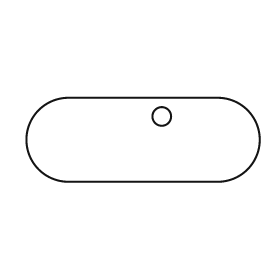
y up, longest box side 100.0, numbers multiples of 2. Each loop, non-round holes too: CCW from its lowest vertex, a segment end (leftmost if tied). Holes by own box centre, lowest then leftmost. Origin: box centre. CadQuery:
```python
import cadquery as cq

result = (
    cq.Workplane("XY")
    .moveTo(-32.0, -18.0)
    .lineTo(32.0, -18.0)
    .threePointArc((50.0, 0.0), (32.0, 18.0))
    .lineTo(-32.0, 18.0)
    .threePointArc((-50.0, 0.0), (-32.0, -18.0))
    .close()
    .moveTo(8.0, 10.0)
    .circle(4.0)
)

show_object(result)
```